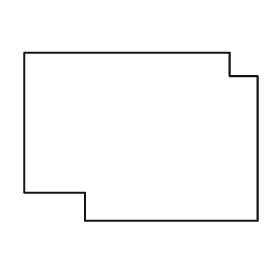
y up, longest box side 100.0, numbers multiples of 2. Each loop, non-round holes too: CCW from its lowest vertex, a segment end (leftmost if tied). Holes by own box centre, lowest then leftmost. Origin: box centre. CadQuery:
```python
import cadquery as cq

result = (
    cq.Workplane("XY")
    .moveTo(-24.0, -36.0)
    .lineTo(50.0, -36.0)
    .lineTo(50.0, 26.0)
    .lineTo(38.0, 26.0)
    .lineTo(38.0, 36.0)
    .lineTo(-50.0, 36.0)
    .lineTo(-50.0, -24.0)
    .lineTo(-24.0, -24.0)
    .close()
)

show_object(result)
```